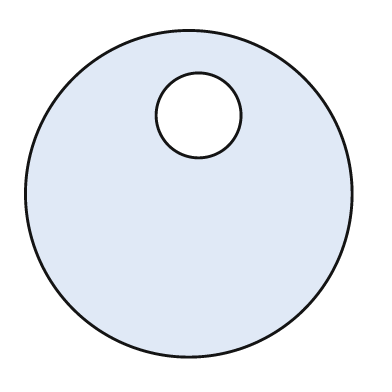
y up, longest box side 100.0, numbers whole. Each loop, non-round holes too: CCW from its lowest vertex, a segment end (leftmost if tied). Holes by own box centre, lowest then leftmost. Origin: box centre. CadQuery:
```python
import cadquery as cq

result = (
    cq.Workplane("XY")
    .moveTo(0.0, 0.0)
    .circle(50.0)
    .moveTo(3.0, 24.0)
    .circle(13.0)
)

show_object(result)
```